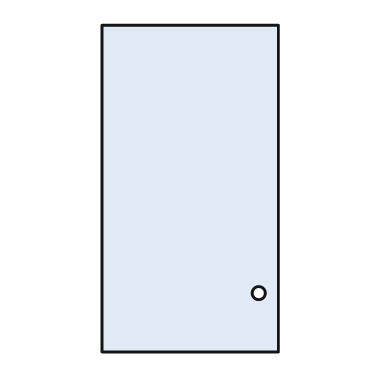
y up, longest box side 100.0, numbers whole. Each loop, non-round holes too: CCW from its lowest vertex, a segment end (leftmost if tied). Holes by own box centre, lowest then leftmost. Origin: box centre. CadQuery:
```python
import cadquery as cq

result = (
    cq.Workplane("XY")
    .moveTo(-27.0, -50.0)
    .lineTo(27.0, -50.0)
    .lineTo(27.0, 50.0)
    .lineTo(-27.0, 50.0)
    .close()
    .moveTo(21.0, -32.0)
    .circle(2.0)
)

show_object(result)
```